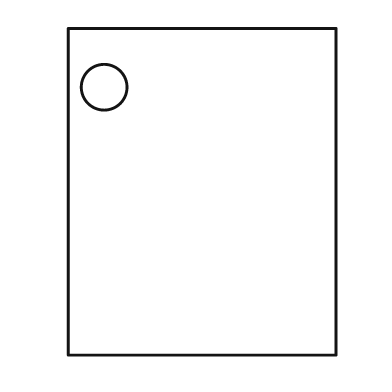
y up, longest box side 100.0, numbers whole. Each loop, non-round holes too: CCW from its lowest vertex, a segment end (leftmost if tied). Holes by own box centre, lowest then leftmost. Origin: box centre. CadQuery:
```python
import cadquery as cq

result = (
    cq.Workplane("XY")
    .moveTo(-41.0, -50.0)
    .lineTo(41.0, -50.0)
    .lineTo(41.0, 50.0)
    .lineTo(-41.0, 50.0)
    .close()
    .moveTo(-30.0, 32.0)
    .circle(7.0)
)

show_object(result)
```